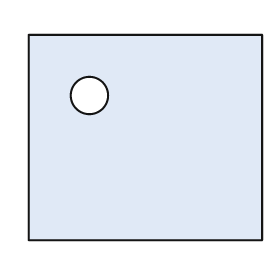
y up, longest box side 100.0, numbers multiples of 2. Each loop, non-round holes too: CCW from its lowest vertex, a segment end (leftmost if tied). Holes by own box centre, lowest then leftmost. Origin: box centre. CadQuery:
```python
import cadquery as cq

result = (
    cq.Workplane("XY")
    .moveTo(-50.0, -44.0)
    .lineTo(50.0, -44.0)
    .lineTo(50.0, 44.0)
    .lineTo(-50.0, 44.0)
    .close()
    .moveTo(-24.0, 18.0)
    .circle(8.0)
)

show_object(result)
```